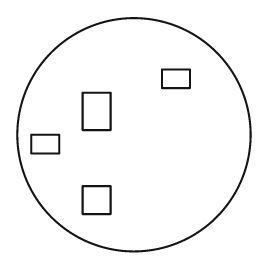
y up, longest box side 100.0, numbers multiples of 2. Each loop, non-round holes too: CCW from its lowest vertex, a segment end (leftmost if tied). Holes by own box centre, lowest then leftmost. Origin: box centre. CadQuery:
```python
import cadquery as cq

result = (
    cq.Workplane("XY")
    .moveTo(0.0, 0.0)
    .circle(50.0)
    .moveTo(-22.0, -34.0)
    .lineTo(-10.0, -34.0)
    .lineTo(-10.0, -22.0)
    .lineTo(-22.0, -22.0)
    .close()
    .moveTo(-44.0, -8.0)
    .lineTo(-32.0, -8.0)
    .lineTo(-32.0, 0.0)
    .lineTo(-44.0, 0.0)
    .close()
    .moveTo(-22.0, 2.0)
    .lineTo(-10.0, 2.0)
    .lineTo(-10.0, 18.0)
    .lineTo(-22.0, 18.0)
    .close()
    .moveTo(12.0, 20.0)
    .lineTo(24.0, 20.0)
    .lineTo(24.0, 28.0)
    .lineTo(12.0, 28.0)
    .close()
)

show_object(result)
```